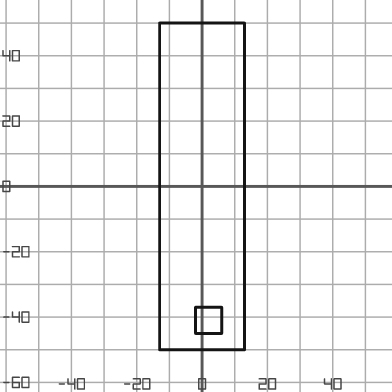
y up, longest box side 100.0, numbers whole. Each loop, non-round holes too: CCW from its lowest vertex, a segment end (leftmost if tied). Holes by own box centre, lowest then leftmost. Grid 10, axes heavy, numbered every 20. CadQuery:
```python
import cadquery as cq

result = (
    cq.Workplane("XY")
    .moveTo(-13.0, -50.0)
    .lineTo(13.0, -50.0)
    .lineTo(13.0, 50.0)
    .lineTo(-13.0, 50.0)
    .close()
    .moveTo(-2.0, -45.0)
    .lineTo(6.0, -45.0)
    .lineTo(6.0, -37.0)
    .lineTo(-2.0, -37.0)
    .close()
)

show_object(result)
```